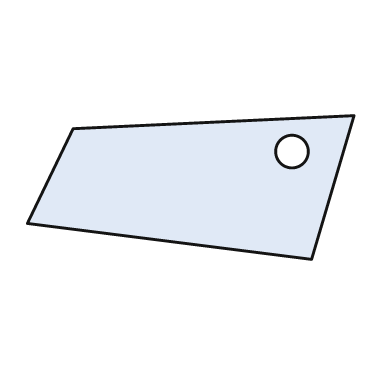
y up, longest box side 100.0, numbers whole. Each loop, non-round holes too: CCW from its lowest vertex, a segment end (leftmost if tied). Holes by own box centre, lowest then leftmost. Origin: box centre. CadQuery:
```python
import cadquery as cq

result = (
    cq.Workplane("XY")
    .moveTo(37.0, -22.0)
    .lineTo(50.0, 22.0)
    .lineTo(-36.0, 18.0)
    .lineTo(-50.0, -11.0)
    .close()
    .moveTo(31.0, 11.0)
    .circle(5.0)
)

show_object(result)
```